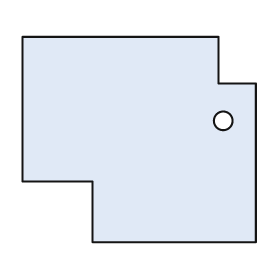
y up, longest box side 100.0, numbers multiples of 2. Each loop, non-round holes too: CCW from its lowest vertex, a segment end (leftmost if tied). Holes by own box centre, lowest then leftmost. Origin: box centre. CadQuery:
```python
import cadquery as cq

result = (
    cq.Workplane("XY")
    .moveTo(-20.0, -44.0)
    .lineTo(50.0, -44.0)
    .lineTo(50.0, 24.0)
    .lineTo(34.0, 24.0)
    .lineTo(34.0, 44.0)
    .lineTo(-50.0, 44.0)
    .lineTo(-50.0, -18.0)
    .lineTo(-20.0, -18.0)
    .close()
    .moveTo(36.0, 8.0)
    .circle(4.0)
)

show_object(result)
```